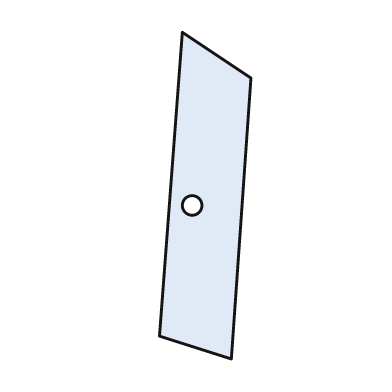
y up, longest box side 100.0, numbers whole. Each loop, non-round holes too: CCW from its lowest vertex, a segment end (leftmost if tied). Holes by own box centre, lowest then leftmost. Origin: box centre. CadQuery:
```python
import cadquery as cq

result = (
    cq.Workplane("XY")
    .moveTo(8.0, -50.0)
    .lineTo(14.0, 36.0)
    .lineTo(-7.0, 50.0)
    .lineTo(-14.0, -43.0)
    .close()
    .moveTo(-4.0, -3.0)
    .circle(3.0)
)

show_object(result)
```